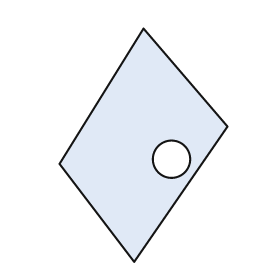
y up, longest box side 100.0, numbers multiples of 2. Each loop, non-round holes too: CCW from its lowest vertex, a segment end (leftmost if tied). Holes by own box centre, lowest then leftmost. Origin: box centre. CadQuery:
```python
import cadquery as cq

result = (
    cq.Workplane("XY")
    .moveTo(-4.0, -50.0)
    .lineTo(36.0, 8.0)
    .lineTo(0.0, 50.0)
    .lineTo(-36.0, -8.0)
    .close()
    .moveTo(12.0, -6.0)
    .circle(8.0)
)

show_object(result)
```